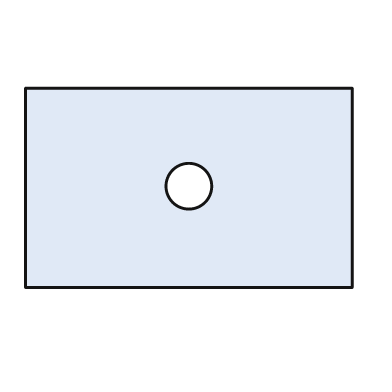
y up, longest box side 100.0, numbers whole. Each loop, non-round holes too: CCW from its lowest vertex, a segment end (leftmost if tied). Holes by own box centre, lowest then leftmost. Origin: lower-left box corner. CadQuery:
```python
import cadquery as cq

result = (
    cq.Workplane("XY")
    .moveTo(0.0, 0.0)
    .lineTo(100.0, 0.0)
    .lineTo(100.0, 61.0)
    .lineTo(0.0, 61.0)
    .close()
    .moveTo(50.0, 31.0)
    .circle(7.0)
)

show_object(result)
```